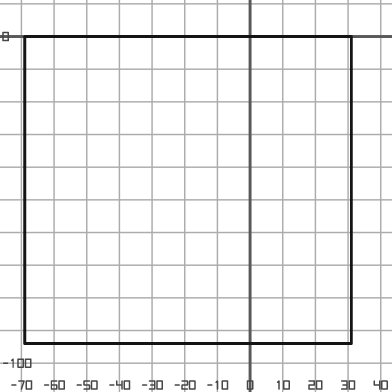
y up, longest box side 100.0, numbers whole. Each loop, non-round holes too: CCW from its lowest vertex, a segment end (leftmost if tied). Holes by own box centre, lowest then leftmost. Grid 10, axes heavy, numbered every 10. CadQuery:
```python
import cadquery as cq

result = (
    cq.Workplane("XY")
    .moveTo(-69.0, -94.0)
    .lineTo(31.0, -94.0)
    .lineTo(31.0, 0.0)
    .lineTo(-69.0, 0.0)
    .close()
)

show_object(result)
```